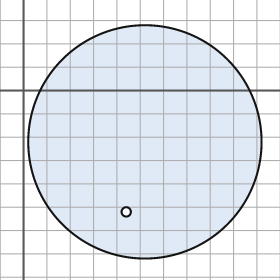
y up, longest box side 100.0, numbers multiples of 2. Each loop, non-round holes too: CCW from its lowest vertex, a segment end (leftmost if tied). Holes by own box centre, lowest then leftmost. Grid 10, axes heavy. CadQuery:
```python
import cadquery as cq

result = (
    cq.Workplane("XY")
    .moveTo(52.0, -22.0)
    .circle(50.0)
    .moveTo(44.0, -52.0)
    .circle(2.0)
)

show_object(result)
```